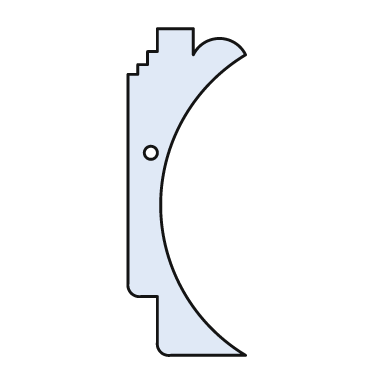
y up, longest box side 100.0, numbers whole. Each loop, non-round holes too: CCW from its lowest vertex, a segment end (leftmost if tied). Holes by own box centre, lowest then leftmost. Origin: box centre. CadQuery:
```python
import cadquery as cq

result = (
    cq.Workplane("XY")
    .moveTo(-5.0, -50.0)
    .lineTo(18.0, -50.0)
    .threePointArc((-8.0, -4.0), (18.0, 42.0))
    .threePointArc((10.0, 47.0), (2.0, 42.0))
    .lineTo(2.0, 50.0)
    .lineTo(-9.0, 50.0)
    .lineTo(-9.0, 43.0)
    .lineTo(-12.0, 43.0)
    .lineTo(-12.0, 39.0)
    .lineTo(-15.0, 39.0)
    .lineTo(-15.0, 36.0)
    .lineTo(-18.0, 36.0)
    .lineTo(-18.0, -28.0)
    .threePointArc((-17.0, -31.0), (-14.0, -32.0))
    .lineTo(-9.0, -32.0)
    .lineTo(-9.0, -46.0)
    .threePointArc((-8.0, -49.0), (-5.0, -50.0))
    .close()
    .moveTo(-11.0, 12.0)
    .circle(2.0)
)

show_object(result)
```